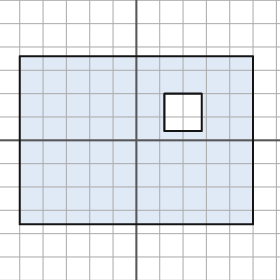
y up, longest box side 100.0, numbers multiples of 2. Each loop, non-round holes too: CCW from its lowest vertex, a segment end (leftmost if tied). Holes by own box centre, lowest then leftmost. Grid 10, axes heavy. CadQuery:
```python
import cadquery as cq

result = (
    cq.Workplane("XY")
    .moveTo(-50.0, -36.0)
    .lineTo(50.0, -36.0)
    .lineTo(50.0, 36.0)
    .lineTo(-50.0, 36.0)
    .close()
    .moveTo(12.0, 4.0)
    .lineTo(28.0, 4.0)
    .lineTo(28.0, 20.0)
    .lineTo(12.0, 20.0)
    .close()
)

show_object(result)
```